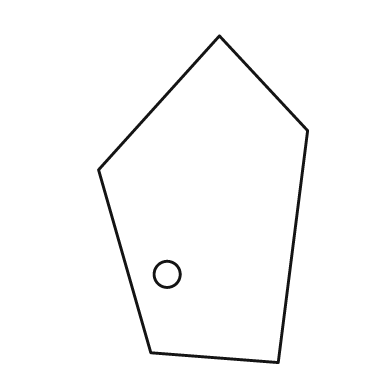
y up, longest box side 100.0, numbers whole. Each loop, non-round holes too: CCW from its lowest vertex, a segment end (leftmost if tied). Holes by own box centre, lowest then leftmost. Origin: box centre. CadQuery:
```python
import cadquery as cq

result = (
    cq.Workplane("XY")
    .moveTo(23.0, -50.0)
    .lineTo(32.0, 21.0)
    .lineTo(5.0, 50.0)
    .lineTo(-32.0, 9.0)
    .lineTo(-16.0, -47.0)
    .close()
    .moveTo(-11.0, -23.0)
    .circle(4.0)
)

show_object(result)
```